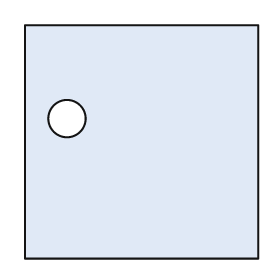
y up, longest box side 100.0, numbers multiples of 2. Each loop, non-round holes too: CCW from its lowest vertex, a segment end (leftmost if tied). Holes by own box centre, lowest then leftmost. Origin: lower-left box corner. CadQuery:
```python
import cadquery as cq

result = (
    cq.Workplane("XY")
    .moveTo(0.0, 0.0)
    .lineTo(100.0, 0.0)
    .lineTo(100.0, 100.0)
    .lineTo(0.0, 100.0)
    .close()
    .moveTo(18.0, 60.0)
    .circle(8.0)
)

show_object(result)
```